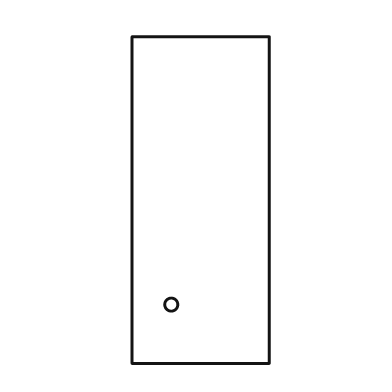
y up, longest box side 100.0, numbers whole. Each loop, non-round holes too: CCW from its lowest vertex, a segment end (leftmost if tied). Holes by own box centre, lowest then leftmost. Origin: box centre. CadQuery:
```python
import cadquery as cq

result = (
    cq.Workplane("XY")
    .moveTo(-21.0, -50.0)
    .lineTo(21.0, -50.0)
    .lineTo(21.0, 50.0)
    .lineTo(-21.0, 50.0)
    .close()
    .moveTo(-9.0, -32.0)
    .circle(2.0)
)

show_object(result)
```